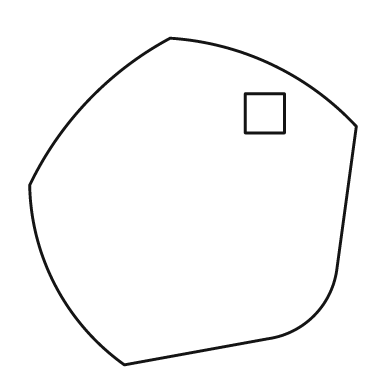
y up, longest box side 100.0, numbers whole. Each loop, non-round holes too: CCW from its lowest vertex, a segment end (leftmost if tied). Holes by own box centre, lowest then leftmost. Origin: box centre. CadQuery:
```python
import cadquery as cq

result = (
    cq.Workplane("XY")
    .moveTo(-21.0, -50.0)
    .lineTo(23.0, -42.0)
    .threePointArc((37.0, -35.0), (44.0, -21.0))
    .lineTo(50.0, 23.0)
    .threePointArc((24.0, 42.0), (-7.0, 50.0))
    .threePointArc((-32.0, 31.0), (-50.0, 5.0))
    .threePointArc((-42.0, -26.0), (-21.0, -50.0))
    .close()
    .moveTo(16.0, 21.0)
    .lineTo(28.0, 21.0)
    .lineTo(28.0, 33.0)
    .lineTo(16.0, 33.0)
    .close()
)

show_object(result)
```